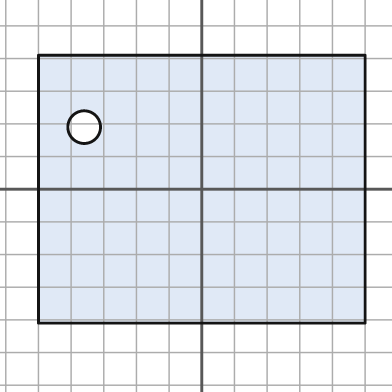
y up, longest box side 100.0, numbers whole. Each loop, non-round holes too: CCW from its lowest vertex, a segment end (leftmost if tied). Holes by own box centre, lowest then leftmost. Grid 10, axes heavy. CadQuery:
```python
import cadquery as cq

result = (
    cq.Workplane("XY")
    .moveTo(-50.0, -41.0)
    .lineTo(50.0, -41.0)
    .lineTo(50.0, 41.0)
    .lineTo(-50.0, 41.0)
    .close()
    .moveTo(-36.0, 19.0)
    .circle(5.0)
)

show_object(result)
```